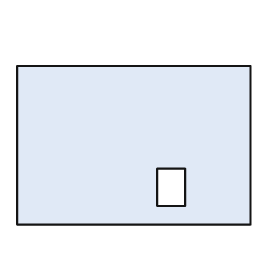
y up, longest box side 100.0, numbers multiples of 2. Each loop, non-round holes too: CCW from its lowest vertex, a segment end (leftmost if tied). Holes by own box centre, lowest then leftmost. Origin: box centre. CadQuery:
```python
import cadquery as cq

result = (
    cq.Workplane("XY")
    .moveTo(-50.0, -34.0)
    .lineTo(50.0, -34.0)
    .lineTo(50.0, 34.0)
    .lineTo(-50.0, 34.0)
    .close()
    .moveTo(10.0, -26.0)
    .lineTo(22.0, -26.0)
    .lineTo(22.0, -10.0)
    .lineTo(10.0, -10.0)
    .close()
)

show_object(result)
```